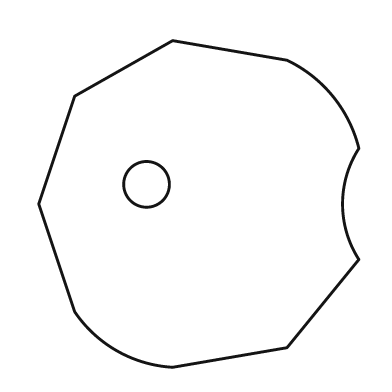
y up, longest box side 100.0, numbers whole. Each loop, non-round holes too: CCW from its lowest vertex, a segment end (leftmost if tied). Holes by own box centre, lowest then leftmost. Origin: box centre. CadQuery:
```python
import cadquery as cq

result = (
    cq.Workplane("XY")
    .moveTo(-8.0, -50.0)
    .lineTo(27.0, -44.0)
    .lineTo(49.0, -17.0)
    .threePointArc((44.0, 0.0), (49.0, 17.0))
    .threePointArc((41.0, 33.0), (27.0, 44.0))
    .lineTo(-8.0, 50.0)
    .lineTo(-38.0, 33.0)
    .lineTo(-49.0, 0.0)
    .lineTo(-38.0, -33.0)
    .threePointArc((-25.0, -45.0), (-8.0, -50.0))
    .close()
    .moveTo(-16.0, 6.0)
    .circle(7.0)
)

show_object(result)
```